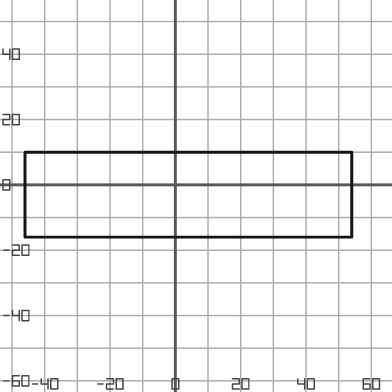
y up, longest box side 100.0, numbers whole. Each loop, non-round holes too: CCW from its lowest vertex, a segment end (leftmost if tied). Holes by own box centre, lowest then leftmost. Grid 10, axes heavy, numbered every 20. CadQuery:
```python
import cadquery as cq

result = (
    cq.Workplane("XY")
    .moveTo(-46.0, -16.0)
    .lineTo(54.0, -16.0)
    .lineTo(54.0, 10.0)
    .lineTo(-46.0, 10.0)
    .close()
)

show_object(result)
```